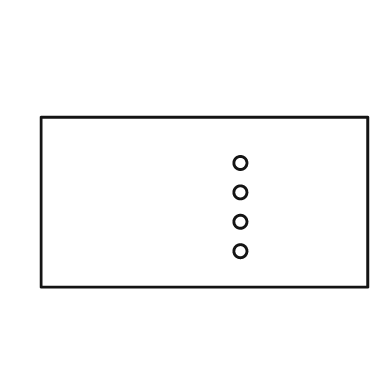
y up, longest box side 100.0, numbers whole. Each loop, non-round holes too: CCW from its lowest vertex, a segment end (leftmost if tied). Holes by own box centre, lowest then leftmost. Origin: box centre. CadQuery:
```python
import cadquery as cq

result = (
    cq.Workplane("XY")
    .moveTo(-50.0, -26.0)
    .lineTo(50.0, -26.0)
    .lineTo(50.0, 26.0)
    .lineTo(-50.0, 26.0)
    .close()
    .moveTo(11.0, -15.0)
    .circle(2.0)
    .moveTo(11.0, -6.0)
    .circle(2.0)
    .moveTo(11.0, 3.0)
    .circle(2.0)
    .moveTo(11.0, 12.0)
    .circle(2.0)
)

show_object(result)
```